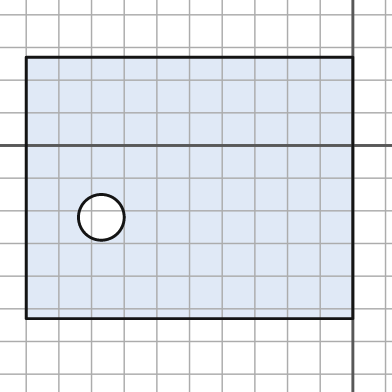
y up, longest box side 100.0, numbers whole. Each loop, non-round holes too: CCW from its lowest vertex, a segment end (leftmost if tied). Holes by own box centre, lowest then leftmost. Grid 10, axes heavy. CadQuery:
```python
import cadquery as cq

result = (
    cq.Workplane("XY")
    .moveTo(-100.0, -53.0)
    .lineTo(0.0, -53.0)
    .lineTo(0.0, 27.0)
    .lineTo(-100.0, 27.0)
    .close()
    .moveTo(-77.0, -22.0)
    .circle(7.0)
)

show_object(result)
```